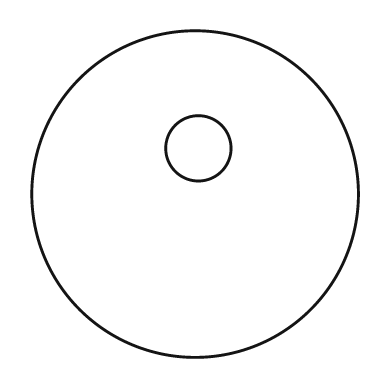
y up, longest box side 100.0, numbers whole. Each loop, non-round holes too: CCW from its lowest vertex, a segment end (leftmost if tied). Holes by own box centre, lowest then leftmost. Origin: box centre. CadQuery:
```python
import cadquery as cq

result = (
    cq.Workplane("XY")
    .moveTo(0.0, 0.0)
    .circle(50.0)
    .moveTo(1.0, 14.0)
    .circle(10.0)
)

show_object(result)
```